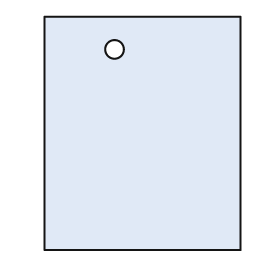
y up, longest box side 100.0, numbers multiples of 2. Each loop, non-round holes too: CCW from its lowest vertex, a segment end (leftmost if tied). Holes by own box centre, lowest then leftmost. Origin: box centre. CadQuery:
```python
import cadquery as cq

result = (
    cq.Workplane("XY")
    .moveTo(-42.0, -50.0)
    .lineTo(42.0, -50.0)
    .lineTo(42.0, 50.0)
    .lineTo(-42.0, 50.0)
    .close()
    .moveTo(-12.0, 36.0)
    .circle(4.0)
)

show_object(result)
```